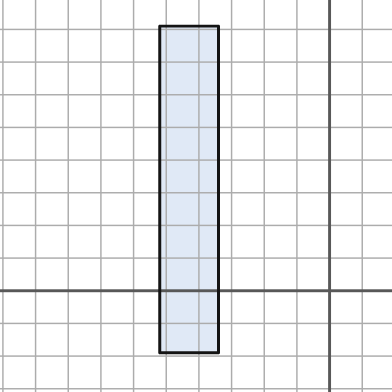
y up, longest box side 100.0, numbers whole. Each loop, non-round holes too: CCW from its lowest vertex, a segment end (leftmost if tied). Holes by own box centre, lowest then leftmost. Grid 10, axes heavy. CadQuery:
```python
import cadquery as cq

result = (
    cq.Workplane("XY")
    .moveTo(-52.0, -19.0)
    .lineTo(-34.0, -19.0)
    .lineTo(-34.0, 81.0)
    .lineTo(-52.0, 81.0)
    .close()
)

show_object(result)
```